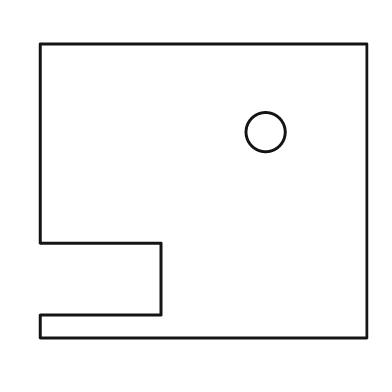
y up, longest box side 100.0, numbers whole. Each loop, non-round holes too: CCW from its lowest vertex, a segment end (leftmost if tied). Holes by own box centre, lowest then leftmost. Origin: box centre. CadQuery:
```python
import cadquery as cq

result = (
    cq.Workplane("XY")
    .moveTo(-50.0, -45.0)
    .lineTo(50.0, -45.0)
    .lineTo(50.0, 45.0)
    .lineTo(-50.0, 45.0)
    .lineTo(-50.0, -16.0)
    .lineTo(-13.0, -16.0)
    .lineTo(-13.0, -38.0)
    .lineTo(-50.0, -38.0)
    .close()
    .moveTo(19.0, 18.0)
    .circle(6.0)
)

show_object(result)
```